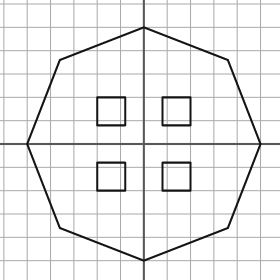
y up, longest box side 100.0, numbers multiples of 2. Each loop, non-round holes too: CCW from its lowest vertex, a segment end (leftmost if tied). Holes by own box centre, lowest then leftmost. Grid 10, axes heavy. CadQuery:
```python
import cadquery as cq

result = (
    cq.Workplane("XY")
    .moveTo(0.0, -50.0)
    .lineTo(36.0, -36.0)
    .lineTo(50.0, 0.0)
    .lineTo(36.0, 36.0)
    .lineTo(0.0, 50.0)
    .lineTo(-36.0, 36.0)
    .lineTo(-50.0, 0.0)
    .lineTo(-36.0, -36.0)
    .close()
    .moveTo(-20.0, -20.0)
    .lineTo(-8.0, -20.0)
    .lineTo(-8.0, -8.0)
    .lineTo(-20.0, -8.0)
    .close()
    .moveTo(8.0, -20.0)
    .lineTo(20.0, -20.0)
    .lineTo(20.0, -8.0)
    .lineTo(8.0, -8.0)
    .close()
    .moveTo(-20.0, 8.0)
    .lineTo(-8.0, 8.0)
    .lineTo(-8.0, 20.0)
    .lineTo(-20.0, 20.0)
    .close()
    .moveTo(8.0, 8.0)
    .lineTo(20.0, 8.0)
    .lineTo(20.0, 20.0)
    .lineTo(8.0, 20.0)
    .close()
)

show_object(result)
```